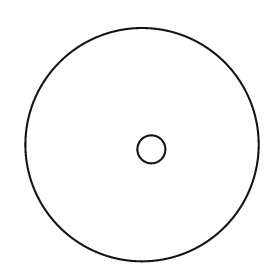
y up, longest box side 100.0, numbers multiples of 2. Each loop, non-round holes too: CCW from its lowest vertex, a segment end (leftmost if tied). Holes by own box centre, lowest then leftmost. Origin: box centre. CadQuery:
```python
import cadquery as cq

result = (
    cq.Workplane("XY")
    .moveTo(0.0, 0.0)
    .circle(50.0)
    .moveTo(4.0, -2.0)
    .circle(6.0)
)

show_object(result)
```